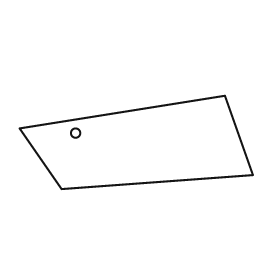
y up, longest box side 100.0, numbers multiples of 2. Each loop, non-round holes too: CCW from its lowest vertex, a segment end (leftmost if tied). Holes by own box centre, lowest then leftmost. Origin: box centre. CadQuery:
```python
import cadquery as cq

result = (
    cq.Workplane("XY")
    .moveTo(-32.0, -20.0)
    .lineTo(50.0, -14.0)
    .lineTo(38.0, 20.0)
    .lineTo(-50.0, 6.0)
    .close()
    .moveTo(-26.0, 4.0)
    .circle(2.0)
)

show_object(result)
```